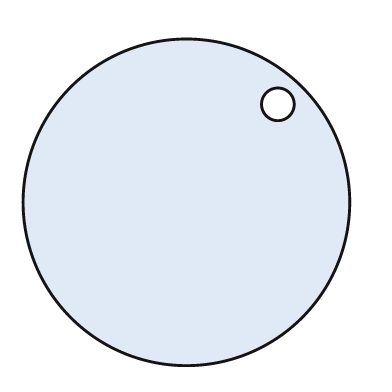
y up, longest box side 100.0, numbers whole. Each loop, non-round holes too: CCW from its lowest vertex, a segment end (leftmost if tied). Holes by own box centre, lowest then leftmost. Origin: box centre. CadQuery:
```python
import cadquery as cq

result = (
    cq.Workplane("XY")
    .moveTo(0.0, 0.0)
    .circle(50.0)
    .moveTo(28.0, 30.0)
    .circle(5.0)
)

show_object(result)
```